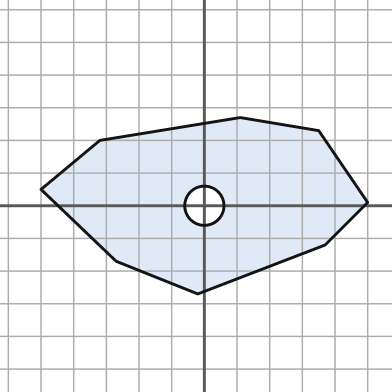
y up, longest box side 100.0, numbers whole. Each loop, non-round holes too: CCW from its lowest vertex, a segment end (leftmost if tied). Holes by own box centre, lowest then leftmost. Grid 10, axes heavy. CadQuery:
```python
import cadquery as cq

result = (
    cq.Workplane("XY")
    .moveTo(-2.0, -27.0)
    .lineTo(37.0, -12.0)
    .lineTo(50.0, 1.0)
    .lineTo(35.0, 23.0)
    .lineTo(11.0, 27.0)
    .lineTo(-32.0, 20.0)
    .lineTo(-50.0, 5.0)
    .lineTo(-27.0, -17.0)
    .close()
    .moveTo(0.0, 0.0)
    .circle(6.0)
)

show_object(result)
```